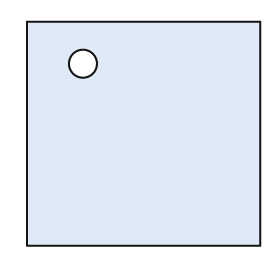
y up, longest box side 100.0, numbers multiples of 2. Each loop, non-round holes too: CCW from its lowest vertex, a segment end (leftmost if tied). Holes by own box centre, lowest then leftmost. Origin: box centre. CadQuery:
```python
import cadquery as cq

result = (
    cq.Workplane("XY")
    .moveTo(-50.0, -48.0)
    .lineTo(50.0, -48.0)
    .lineTo(50.0, 48.0)
    .lineTo(-50.0, 48.0)
    .close()
    .moveTo(-26.0, 30.0)
    .circle(6.0)
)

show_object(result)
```